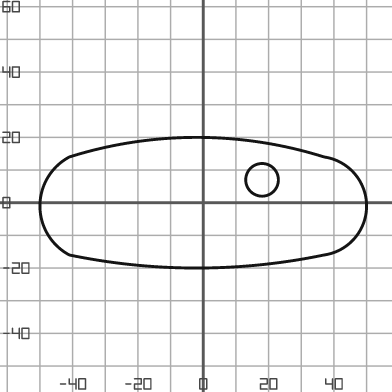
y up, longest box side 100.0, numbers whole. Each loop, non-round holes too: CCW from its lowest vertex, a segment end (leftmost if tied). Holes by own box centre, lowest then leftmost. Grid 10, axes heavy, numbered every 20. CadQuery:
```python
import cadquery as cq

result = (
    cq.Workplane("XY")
    .moveTo(-41.0, -16.0)
    .threePointArc((-2.0, -20.0), (37.0, -16.0))
    .threePointArc((50.0, -1.0), (37.0, 14.0))
    .threePointArc((-2.0, 20.0), (-41.0, 14.0))
    .threePointArc((-50.0, -1.0), (-41.0, -16.0))
    .close()
    .moveTo(18.0, 7.0)
    .circle(5.0)
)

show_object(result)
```